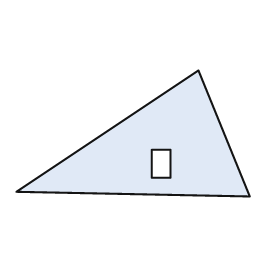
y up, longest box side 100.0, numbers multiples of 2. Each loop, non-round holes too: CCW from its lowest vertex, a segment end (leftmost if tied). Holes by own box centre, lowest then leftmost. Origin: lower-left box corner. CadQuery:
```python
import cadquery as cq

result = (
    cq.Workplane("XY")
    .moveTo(100.0, 0.0)
    .lineTo(78.0, 54.0)
    .lineTo(0.0, 2.0)
    .close()
    .moveTo(58.0, 8.0)
    .lineTo(66.0, 8.0)
    .lineTo(66.0, 20.0)
    .lineTo(58.0, 20.0)
    .close()
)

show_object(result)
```